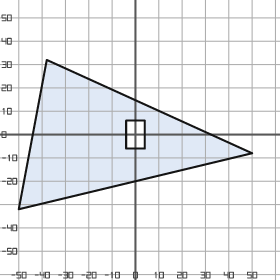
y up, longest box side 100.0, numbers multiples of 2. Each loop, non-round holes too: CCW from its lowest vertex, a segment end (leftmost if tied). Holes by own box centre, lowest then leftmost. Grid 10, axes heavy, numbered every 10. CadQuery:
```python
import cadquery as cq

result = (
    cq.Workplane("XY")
    .moveTo(-50.0, -32.0)
    .lineTo(50.0, -8.0)
    .lineTo(-38.0, 32.0)
    .close()
    .moveTo(-4.0, -6.0)
    .lineTo(4.0, -6.0)
    .lineTo(4.0, 6.0)
    .lineTo(-4.0, 6.0)
    .close()
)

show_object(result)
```